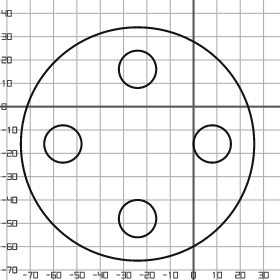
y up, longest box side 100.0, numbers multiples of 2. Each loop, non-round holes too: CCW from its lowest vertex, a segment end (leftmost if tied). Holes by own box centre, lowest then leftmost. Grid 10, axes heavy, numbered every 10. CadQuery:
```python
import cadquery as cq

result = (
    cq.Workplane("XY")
    .moveTo(-24.0, -16.0)
    .circle(50.0)
    .moveTo(-24.0, -48.0)
    .circle(8.0)
    .moveTo(-56.0, -16.0)
    .circle(8.0)
    .moveTo(8.0, -16.0)
    .circle(8.0)
    .moveTo(-24.0, 16.0)
    .circle(8.0)
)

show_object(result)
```